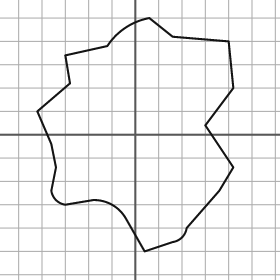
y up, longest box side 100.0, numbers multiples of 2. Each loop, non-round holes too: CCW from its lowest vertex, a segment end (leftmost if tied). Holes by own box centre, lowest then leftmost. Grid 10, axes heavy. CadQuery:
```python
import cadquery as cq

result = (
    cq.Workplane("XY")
    .moveTo(4.0, -50.0)
    .lineTo(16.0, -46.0)
    .threePointArc((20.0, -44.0), (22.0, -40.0))
    .lineTo(36.0, -24.0)
    .lineTo(42.0, -14.0)
    .lineTo(30.0, 4.0)
    .lineTo(42.0, 20.0)
    .lineTo(40.0, 40.0)
    .lineTo(16.0, 42.0)
    .lineTo(6.0, 50.0)
    .threePointArc((-4.0, 46.0), (-12.0, 38.0))
    .lineTo(-30.0, 34.0)
    .lineTo(-28.0, 22.0)
    .lineTo(-42.0, 10.0)
    .lineTo(-36.0, -4.0)
    .lineTo(-34.0, -14.0)
    .lineTo(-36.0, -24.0)
    .threePointArc((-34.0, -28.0), (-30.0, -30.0))
    .lineTo(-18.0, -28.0)
    .threePointArc((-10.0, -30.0), (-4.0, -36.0))
    .close()
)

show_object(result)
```